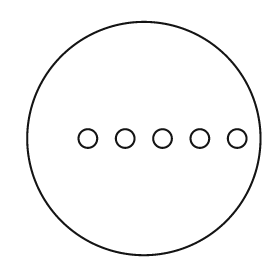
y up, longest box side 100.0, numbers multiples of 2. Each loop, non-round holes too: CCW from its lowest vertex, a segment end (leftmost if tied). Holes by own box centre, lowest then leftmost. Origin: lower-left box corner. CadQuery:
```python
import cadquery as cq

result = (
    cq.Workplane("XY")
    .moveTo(50.0, 50.0)
    .circle(50.0)
    .moveTo(26.0, 50.0)
    .circle(4.0)
    .moveTo(42.0, 50.0)
    .circle(4.0)
    .moveTo(58.0, 50.0)
    .circle(4.0)
    .moveTo(74.0, 50.0)
    .circle(4.0)
    .moveTo(90.0, 50.0)
    .circle(4.0)
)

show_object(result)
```